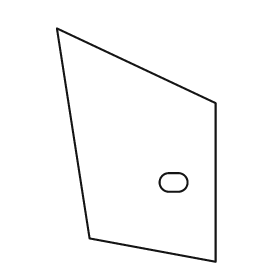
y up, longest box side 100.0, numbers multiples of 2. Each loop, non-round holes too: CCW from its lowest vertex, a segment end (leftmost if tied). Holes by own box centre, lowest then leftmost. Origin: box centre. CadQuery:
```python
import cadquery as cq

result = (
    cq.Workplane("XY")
    .moveTo(34.0, -50.0)
    .lineTo(34.0, 18.0)
    .lineTo(-34.0, 50.0)
    .lineTo(-20.0, -40.0)
    .close()
    .moveTo(14.0, -20.0)
    .lineTo(18.0, -20.0)
    .threePointArc((22.0, -16.0), (18.0, -12.0))
    .lineTo(14.0, -12.0)
    .threePointArc((10.0, -16.0), (14.0, -20.0))
    .close()
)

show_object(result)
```